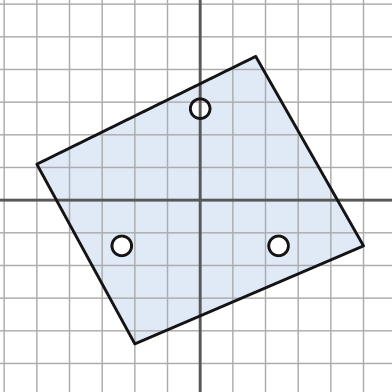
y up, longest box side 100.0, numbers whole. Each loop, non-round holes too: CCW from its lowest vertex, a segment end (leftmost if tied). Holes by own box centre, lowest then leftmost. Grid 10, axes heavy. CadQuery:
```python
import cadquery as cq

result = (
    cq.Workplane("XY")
    .moveTo(-20.0, -44.0)
    .lineTo(50.0, -14.0)
    .lineTo(17.0, 44.0)
    .lineTo(-50.0, 11.0)
    .close()
    .moveTo(-24.0, -14.0)
    .circle(3.0)
    .moveTo(24.0, -14.0)
    .circle(3.0)
    .moveTo(0.0, 28.0)
    .circle(3.0)
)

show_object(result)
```